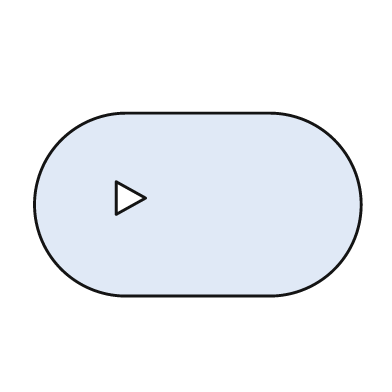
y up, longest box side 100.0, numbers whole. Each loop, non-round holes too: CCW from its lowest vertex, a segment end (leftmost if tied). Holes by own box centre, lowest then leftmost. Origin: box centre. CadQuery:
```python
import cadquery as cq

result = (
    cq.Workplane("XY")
    .moveTo(-22.0, -28.0)
    .lineTo(22.0, -28.0)
    .threePointArc((50.0, 0.0), (22.0, 28.0))
    .lineTo(-22.0, 28.0)
    .threePointArc((-50.0, 0.0), (-22.0, -28.0))
    .close()
    .moveTo(-25.0, -3.0)
    .lineTo(-16.0, 2.0)
    .lineTo(-25.0, 7.0)
    .close()
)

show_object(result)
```